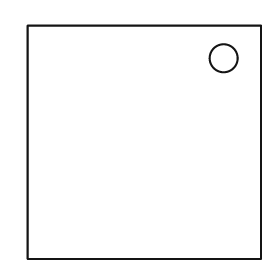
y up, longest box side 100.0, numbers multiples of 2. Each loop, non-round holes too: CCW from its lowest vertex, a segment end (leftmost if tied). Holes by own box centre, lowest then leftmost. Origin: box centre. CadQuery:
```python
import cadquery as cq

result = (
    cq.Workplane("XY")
    .moveTo(-50.0, -50.0)
    .lineTo(50.0, -50.0)
    .lineTo(50.0, 50.0)
    .lineTo(-50.0, 50.0)
    .close()
    .moveTo(34.0, 36.0)
    .circle(6.0)
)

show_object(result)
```